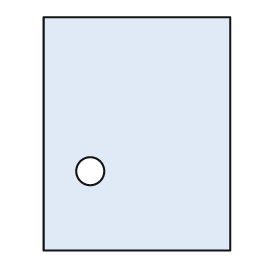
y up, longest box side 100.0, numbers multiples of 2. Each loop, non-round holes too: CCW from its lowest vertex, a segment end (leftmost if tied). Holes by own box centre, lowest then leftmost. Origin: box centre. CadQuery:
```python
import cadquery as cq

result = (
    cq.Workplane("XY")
    .moveTo(-40.0, -50.0)
    .lineTo(40.0, -50.0)
    .lineTo(40.0, 50.0)
    .lineTo(-40.0, 50.0)
    .close()
    .moveTo(-20.0, -16.0)
    .circle(6.0)
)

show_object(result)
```